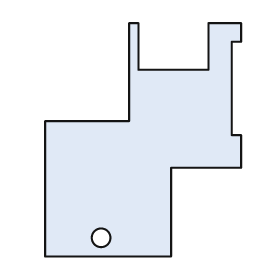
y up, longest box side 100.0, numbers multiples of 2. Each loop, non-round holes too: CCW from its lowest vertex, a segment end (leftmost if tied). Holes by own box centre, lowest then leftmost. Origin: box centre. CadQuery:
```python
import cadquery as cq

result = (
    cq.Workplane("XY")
    .moveTo(-42.0, -50.0)
    .lineTo(12.0, -50.0)
    .lineTo(12.0, -12.0)
    .lineTo(42.0, -12.0)
    .lineTo(42.0, 2.0)
    .lineTo(38.0, 2.0)
    .lineTo(38.0, 42.0)
    .lineTo(42.0, 42.0)
    .lineTo(42.0, 50.0)
    .lineTo(28.0, 50.0)
    .lineTo(28.0, 30.0)
    .lineTo(-2.0, 30.0)
    .lineTo(-2.0, 50.0)
    .lineTo(-6.0, 50.0)
    .lineTo(-6.0, 8.0)
    .lineTo(-42.0, 8.0)
    .close()
    .moveTo(-18.0, -42.0)
    .circle(4.0)
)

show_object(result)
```